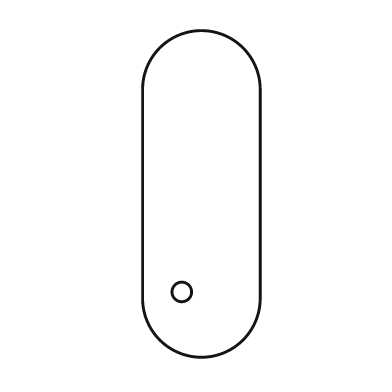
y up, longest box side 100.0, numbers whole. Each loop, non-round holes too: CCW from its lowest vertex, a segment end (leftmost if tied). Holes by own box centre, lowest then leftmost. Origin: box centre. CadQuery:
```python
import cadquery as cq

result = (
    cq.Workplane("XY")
    .moveTo(-18.0, -32.0)
    .threePointArc((0.0, -50.0), (18.0, -32.0))
    .lineTo(18.0, 32.0)
    .threePointArc((0.0, 50.0), (-18.0, 32.0))
    .close()
    .moveTo(-6.0, -30.0)
    .circle(3.0)
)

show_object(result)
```